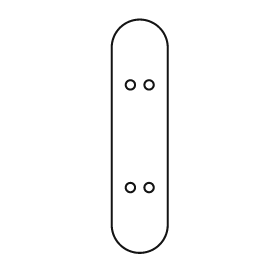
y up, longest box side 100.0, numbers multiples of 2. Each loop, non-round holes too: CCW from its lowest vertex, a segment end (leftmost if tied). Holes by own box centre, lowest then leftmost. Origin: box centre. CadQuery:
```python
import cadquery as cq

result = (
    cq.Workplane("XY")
    .moveTo(-12.0, -38.0)
    .threePointArc((0.0, -50.0), (12.0, -38.0))
    .lineTo(12.0, 38.0)
    .threePointArc((0.0, 50.0), (-12.0, 38.0))
    .close()
    .moveTo(-4.0, -22.0)
    .circle(2.0)
    .moveTo(4.0, -22.0)
    .circle(2.0)
    .moveTo(-4.0, 22.0)
    .circle(2.0)
    .moveTo(4.0, 22.0)
    .circle(2.0)
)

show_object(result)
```